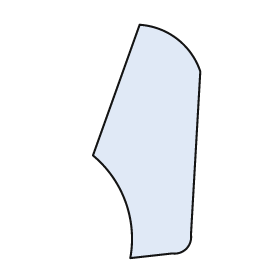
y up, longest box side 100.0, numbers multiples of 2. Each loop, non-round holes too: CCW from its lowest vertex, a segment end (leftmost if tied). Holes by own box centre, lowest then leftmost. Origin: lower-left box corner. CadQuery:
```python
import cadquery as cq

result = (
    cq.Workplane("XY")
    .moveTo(16.0, 0.0)
    .lineTo(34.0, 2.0)
    .threePointArc((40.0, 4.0), (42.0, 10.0))
    .lineTo(46.0, 80.0)
    .threePointArc((36.0, 94.0), (20.0, 100.0))
    .lineTo(0.0, 44.0)
    .threePointArc((14.0, 24.0), (16.0, 0.0))
    .close()
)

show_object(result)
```